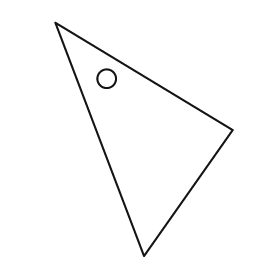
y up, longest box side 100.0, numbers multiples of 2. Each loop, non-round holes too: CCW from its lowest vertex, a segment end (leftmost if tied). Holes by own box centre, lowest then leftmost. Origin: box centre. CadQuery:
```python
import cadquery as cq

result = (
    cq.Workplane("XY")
    .moveTo(0.0, -50.0)
    .lineTo(38.0, 4.0)
    .lineTo(-38.0, 50.0)
    .close()
    .moveTo(-16.0, 26.0)
    .circle(4.0)
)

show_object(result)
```